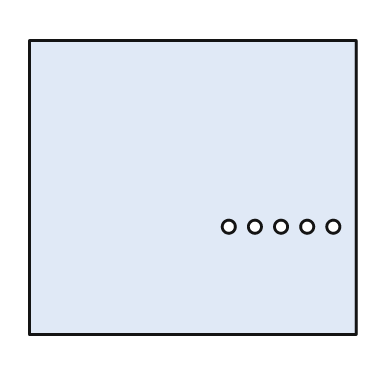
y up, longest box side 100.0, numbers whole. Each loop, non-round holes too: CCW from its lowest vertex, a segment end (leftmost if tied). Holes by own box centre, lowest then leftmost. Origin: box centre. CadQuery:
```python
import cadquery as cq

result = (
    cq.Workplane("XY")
    .moveTo(-50.0, -45.0)
    .lineTo(50.0, -45.0)
    .lineTo(50.0, 45.0)
    .lineTo(-50.0, 45.0)
    .close()
    .moveTo(11.0, -12.0)
    .circle(2.0)
    .moveTo(19.0, -12.0)
    .circle(2.0)
    .moveTo(27.0, -12.0)
    .circle(2.0)
    .moveTo(35.0, -12.0)
    .circle(2.0)
    .moveTo(43.0, -12.0)
    .circle(2.0)
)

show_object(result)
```